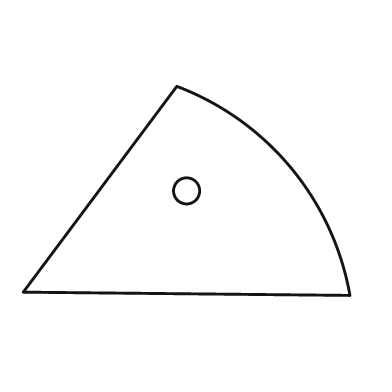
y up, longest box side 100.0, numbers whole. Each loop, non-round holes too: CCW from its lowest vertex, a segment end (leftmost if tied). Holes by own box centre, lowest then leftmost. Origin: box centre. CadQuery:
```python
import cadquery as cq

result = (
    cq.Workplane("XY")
    .moveTo(50.0, -32.0)
    .threePointArc((32.0, 7.0), (-3.0, 32.0))
    .lineTo(-50.0, -31.0)
    .close()
    .moveTo(0.0, 0.0)
    .circle(4.0)
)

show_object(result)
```